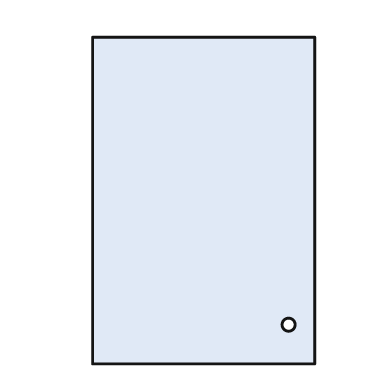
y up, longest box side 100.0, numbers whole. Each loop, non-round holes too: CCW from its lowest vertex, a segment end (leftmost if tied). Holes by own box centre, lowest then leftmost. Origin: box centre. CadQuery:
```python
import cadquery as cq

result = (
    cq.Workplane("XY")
    .moveTo(-34.0, -50.0)
    .lineTo(34.0, -50.0)
    .lineTo(34.0, 50.0)
    .lineTo(-34.0, 50.0)
    .close()
    .moveTo(26.0, -38.0)
    .circle(2.0)
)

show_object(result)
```